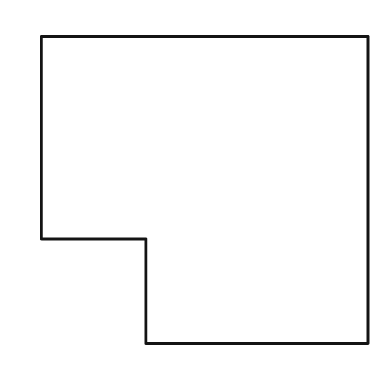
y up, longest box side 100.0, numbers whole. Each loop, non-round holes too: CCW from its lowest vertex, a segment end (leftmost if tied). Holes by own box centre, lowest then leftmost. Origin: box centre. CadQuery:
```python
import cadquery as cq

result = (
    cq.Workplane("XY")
    .moveTo(-18.0, -47.0)
    .lineTo(50.0, -47.0)
    .lineTo(50.0, 47.0)
    .lineTo(-50.0, 47.0)
    .lineTo(-50.0, -15.0)
    .lineTo(-18.0, -15.0)
    .close()
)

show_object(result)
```